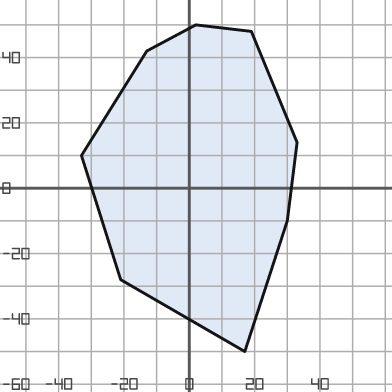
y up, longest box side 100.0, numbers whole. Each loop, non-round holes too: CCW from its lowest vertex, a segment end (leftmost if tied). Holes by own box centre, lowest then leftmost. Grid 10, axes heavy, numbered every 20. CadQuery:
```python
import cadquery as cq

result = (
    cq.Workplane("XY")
    .moveTo(17.0, -50.0)
    .lineTo(30.0, -10.0)
    .lineTo(33.0, 14.0)
    .lineTo(19.0, 48.0)
    .lineTo(2.0, 50.0)
    .lineTo(-13.0, 42.0)
    .lineTo(-33.0, 10.0)
    .lineTo(-21.0, -28.0)
    .close()
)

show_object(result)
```